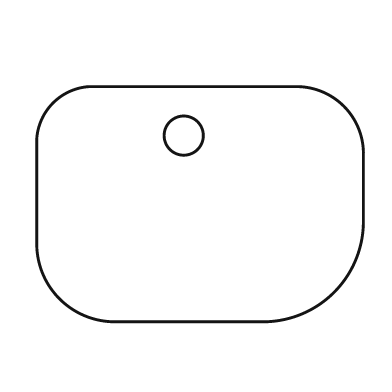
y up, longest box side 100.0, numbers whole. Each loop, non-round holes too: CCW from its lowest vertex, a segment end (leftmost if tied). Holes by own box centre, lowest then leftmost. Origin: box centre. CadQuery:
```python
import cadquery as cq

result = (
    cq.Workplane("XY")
    .moveTo(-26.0, -36.0)
    .lineTo(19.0, -36.0)
    .threePointArc((41.0, -27.0), (50.0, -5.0))
    .lineTo(50.0, 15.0)
    .threePointArc((44.0, 30.0), (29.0, 36.0))
    .lineTo(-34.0, 36.0)
    .threePointArc((-45.0, 31.0), (-50.0, 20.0))
    .lineTo(-50.0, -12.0)
    .threePointArc((-43.0, -29.0), (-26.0, -36.0))
    .close()
    .moveTo(-5.0, 21.0)
    .circle(6.0)
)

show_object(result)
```